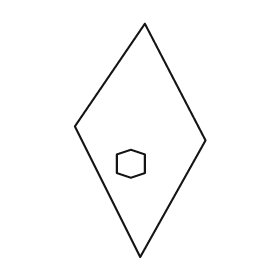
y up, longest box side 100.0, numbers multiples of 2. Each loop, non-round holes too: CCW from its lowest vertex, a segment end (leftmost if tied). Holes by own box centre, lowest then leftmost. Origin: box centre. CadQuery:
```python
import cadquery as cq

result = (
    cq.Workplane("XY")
    .moveTo(0.0, -50.0)
    .lineTo(28.0, 0.0)
    .lineTo(2.0, 50.0)
    .lineTo(-28.0, 6.0)
    .close()
    .moveTo(-4.0, -16.0)
    .lineTo(2.0, -14.0)
    .lineTo(2.0, -6.0)
    .lineTo(-4.0, -4.0)
    .lineTo(-10.0, -6.0)
    .lineTo(-10.0, -14.0)
    .close()
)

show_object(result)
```